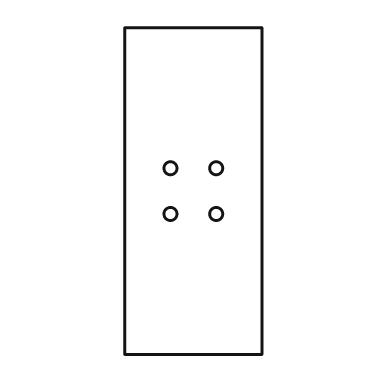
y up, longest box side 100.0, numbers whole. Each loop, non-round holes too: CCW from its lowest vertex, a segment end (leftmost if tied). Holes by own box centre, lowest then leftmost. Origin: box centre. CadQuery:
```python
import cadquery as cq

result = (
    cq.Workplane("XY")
    .moveTo(-21.0, -50.0)
    .lineTo(21.0, -50.0)
    .lineTo(21.0, 50.0)
    .lineTo(-21.0, 50.0)
    .close()
    .moveTo(-7.0, -7.0)
    .circle(2.0)
    .moveTo(7.0, -7.0)
    .circle(2.0)
    .moveTo(-7.0, 7.0)
    .circle(2.0)
    .moveTo(7.0, 7.0)
    .circle(2.0)
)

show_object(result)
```